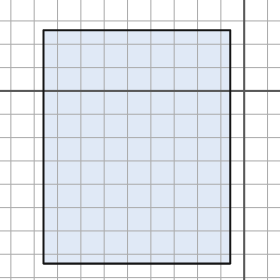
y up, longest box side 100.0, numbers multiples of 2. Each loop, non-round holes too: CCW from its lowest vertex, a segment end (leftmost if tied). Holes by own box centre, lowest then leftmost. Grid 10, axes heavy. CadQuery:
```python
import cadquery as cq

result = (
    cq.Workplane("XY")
    .moveTo(-86.0, -74.0)
    .lineTo(-6.0, -74.0)
    .lineTo(-6.0, 26.0)
    .lineTo(-86.0, 26.0)
    .close()
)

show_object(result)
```